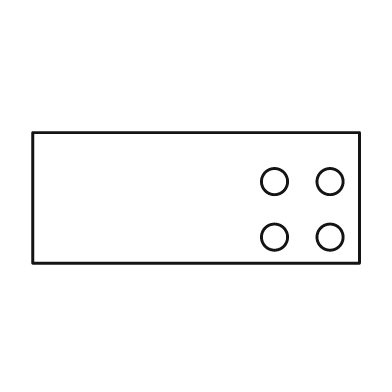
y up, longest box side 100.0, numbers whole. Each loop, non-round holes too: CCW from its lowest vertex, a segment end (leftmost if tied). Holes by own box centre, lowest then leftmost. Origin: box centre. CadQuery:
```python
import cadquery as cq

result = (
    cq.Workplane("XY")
    .moveTo(-50.0, -20.0)
    .lineTo(50.0, -20.0)
    .lineTo(50.0, 20.0)
    .lineTo(-50.0, 20.0)
    .close()
    .moveTo(24.0, -12.0)
    .circle(4.0)
    .moveTo(41.0, -12.0)
    .circle(4.0)
    .moveTo(24.0, 5.0)
    .circle(4.0)
    .moveTo(41.0, 5.0)
    .circle(4.0)
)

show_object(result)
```